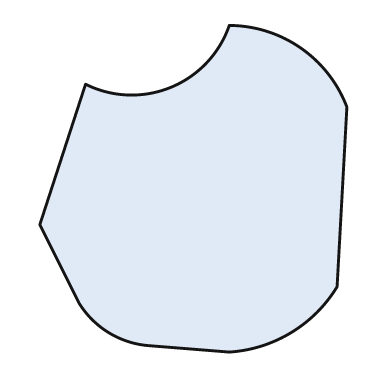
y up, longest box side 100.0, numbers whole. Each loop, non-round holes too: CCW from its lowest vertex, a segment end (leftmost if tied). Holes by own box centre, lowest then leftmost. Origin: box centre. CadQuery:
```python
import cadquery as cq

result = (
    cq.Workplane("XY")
    .moveTo(11.0, -50.0)
    .threePointArc((30.0, -44.0), (44.0, -30.0))
    .lineTo(47.0, 25.0)
    .threePointArc((33.0, 43.0), (11.0, 50.0))
    .threePointArc((-7.0, 31.0), (-33.0, 32.0))
    .lineTo(-47.0, -11.0)
    .lineTo(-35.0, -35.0)
    .threePointArc((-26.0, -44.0), (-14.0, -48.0))
    .close()
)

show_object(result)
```